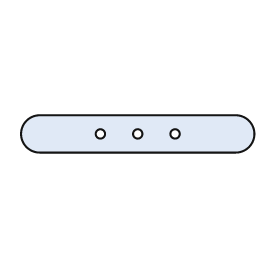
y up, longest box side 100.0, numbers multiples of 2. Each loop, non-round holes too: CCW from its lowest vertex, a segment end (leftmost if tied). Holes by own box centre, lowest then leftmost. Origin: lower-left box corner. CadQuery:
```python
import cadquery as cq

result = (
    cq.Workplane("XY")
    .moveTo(8.0, 0.0)
    .lineTo(92.0, 0.0)
    .threePointArc((100.0, 8.0), (92.0, 16.0))
    .lineTo(8.0, 16.0)
    .threePointArc((0.0, 8.0), (8.0, 0.0))
    .close()
    .moveTo(34.0, 8.0)
    .circle(2.0)
    .moveTo(50.0, 8.0)
    .circle(2.0)
    .moveTo(66.0, 8.0)
    .circle(2.0)
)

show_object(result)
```